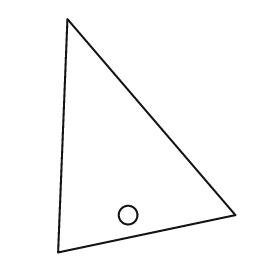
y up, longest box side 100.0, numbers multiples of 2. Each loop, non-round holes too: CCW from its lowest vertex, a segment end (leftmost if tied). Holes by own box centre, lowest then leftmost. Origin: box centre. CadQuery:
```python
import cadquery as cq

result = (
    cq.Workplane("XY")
    .moveTo(-38.0, -50.0)
    .lineTo(38.0, -34.0)
    .lineTo(-34.0, 50.0)
    .close()
    .moveTo(-8.0, -34.0)
    .circle(4.0)
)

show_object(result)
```